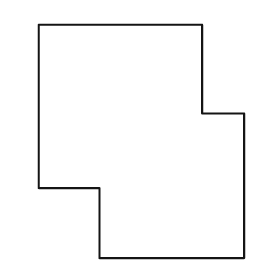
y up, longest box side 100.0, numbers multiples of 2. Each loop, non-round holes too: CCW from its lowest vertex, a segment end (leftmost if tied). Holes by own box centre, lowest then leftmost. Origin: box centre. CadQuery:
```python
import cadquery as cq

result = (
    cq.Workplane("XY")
    .moveTo(-18.0, -50.0)
    .lineTo(44.0, -50.0)
    .lineTo(44.0, 12.0)
    .lineTo(26.0, 12.0)
    .lineTo(26.0, 50.0)
    .lineTo(-44.0, 50.0)
    .lineTo(-44.0, -20.0)
    .lineTo(-18.0, -20.0)
    .close()
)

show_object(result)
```